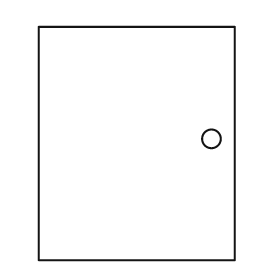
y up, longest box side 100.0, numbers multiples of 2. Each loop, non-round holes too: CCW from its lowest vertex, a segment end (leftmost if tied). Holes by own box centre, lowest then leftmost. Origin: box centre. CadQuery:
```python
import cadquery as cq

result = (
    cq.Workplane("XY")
    .moveTo(-42.0, -50.0)
    .lineTo(42.0, -50.0)
    .lineTo(42.0, 50.0)
    .lineTo(-42.0, 50.0)
    .close()
    .moveTo(32.0, 2.0)
    .circle(4.0)
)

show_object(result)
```